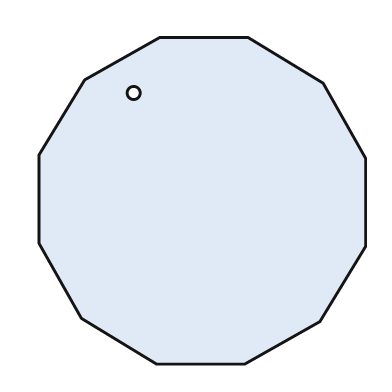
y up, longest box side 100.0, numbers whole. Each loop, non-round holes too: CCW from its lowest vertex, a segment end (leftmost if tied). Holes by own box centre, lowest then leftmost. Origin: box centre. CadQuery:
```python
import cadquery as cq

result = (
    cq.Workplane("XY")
    .moveTo(-14.0, -50.0)
    .lineTo(13.0, -50.0)
    .lineTo(36.0, -37.0)
    .lineTo(50.0, -14.0)
    .lineTo(50.0, 13.0)
    .lineTo(37.0, 36.0)
    .lineTo(14.0, 50.0)
    .lineTo(-13.0, 50.0)
    .lineTo(-36.0, 37.0)
    .lineTo(-50.0, 14.0)
    .lineTo(-50.0, -13.0)
    .lineTo(-37.0, -36.0)
    .close()
    .moveTo(-21.0, 33.0)
    .circle(2.0)
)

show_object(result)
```